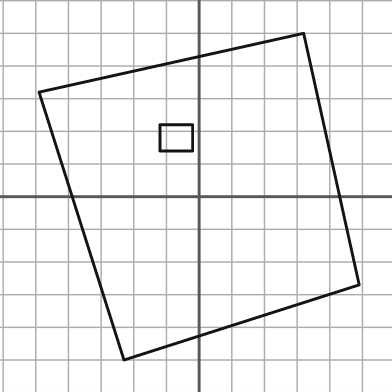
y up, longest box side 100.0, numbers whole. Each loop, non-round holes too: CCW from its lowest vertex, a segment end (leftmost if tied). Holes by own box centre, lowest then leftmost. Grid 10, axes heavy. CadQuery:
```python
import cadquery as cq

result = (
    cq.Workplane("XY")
    .moveTo(-23.0, -50.0)
    .lineTo(49.0, -27.0)
    .lineTo(32.0, 50.0)
    .lineTo(-49.0, 32.0)
    .close()
    .moveTo(-12.0, 14.0)
    .lineTo(-2.0, 14.0)
    .lineTo(-2.0, 22.0)
    .lineTo(-12.0, 22.0)
    .close()
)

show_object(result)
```